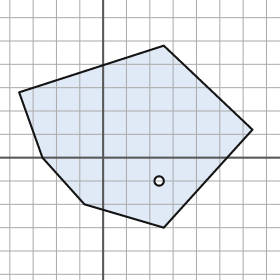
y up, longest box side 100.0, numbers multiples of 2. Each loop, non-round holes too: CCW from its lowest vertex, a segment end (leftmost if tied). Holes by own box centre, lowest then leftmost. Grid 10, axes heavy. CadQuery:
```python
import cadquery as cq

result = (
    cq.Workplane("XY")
    .moveTo(26.0, -30.0)
    .lineTo(64.0, 12.0)
    .lineTo(26.0, 48.0)
    .lineTo(-36.0, 28.0)
    .lineTo(-26.0, 0.0)
    .lineTo(-8.0, -20.0)
    .close()
    .moveTo(24.0, -10.0)
    .circle(2.0)
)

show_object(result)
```